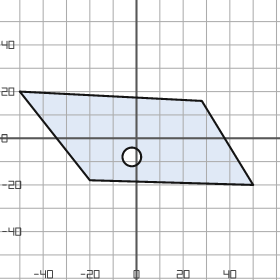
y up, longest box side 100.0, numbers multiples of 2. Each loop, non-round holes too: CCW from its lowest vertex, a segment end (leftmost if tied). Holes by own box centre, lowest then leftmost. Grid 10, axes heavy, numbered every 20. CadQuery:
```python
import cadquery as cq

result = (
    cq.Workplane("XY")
    .moveTo(50.0, -20.0)
    .lineTo(28.0, 16.0)
    .lineTo(-50.0, 20.0)
    .lineTo(-20.0, -18.0)
    .close()
    .moveTo(-2.0, -8.0)
    .circle(4.0)
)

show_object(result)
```